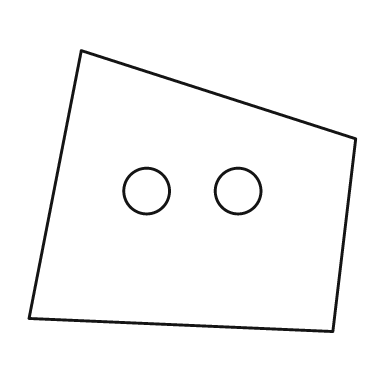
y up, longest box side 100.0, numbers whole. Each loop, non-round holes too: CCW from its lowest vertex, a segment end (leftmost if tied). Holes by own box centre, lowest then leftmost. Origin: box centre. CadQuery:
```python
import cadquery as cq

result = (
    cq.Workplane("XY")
    .moveTo(43.0, -43.0)
    .lineTo(50.0, 16.0)
    .lineTo(-34.0, 43.0)
    .lineTo(-50.0, -39.0)
    .close()
    .moveTo(-14.0, 0.0)
    .circle(7.0)
    .moveTo(14.0, 0.0)
    .circle(7.0)
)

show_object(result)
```